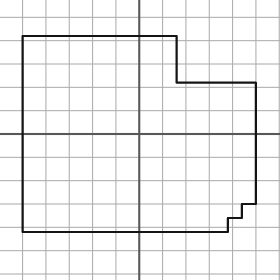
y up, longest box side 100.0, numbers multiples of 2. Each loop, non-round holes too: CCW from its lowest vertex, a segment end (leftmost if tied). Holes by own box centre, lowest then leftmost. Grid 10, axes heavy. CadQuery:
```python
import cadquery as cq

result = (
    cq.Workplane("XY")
    .moveTo(-50.0, -42.0)
    .lineTo(38.0, -42.0)
    .lineTo(38.0, -36.0)
    .lineTo(44.0, -36.0)
    .lineTo(44.0, -30.0)
    .lineTo(50.0, -30.0)
    .lineTo(50.0, 22.0)
    .lineTo(16.0, 22.0)
    .lineTo(16.0, 42.0)
    .lineTo(-50.0, 42.0)
    .close()
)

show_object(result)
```